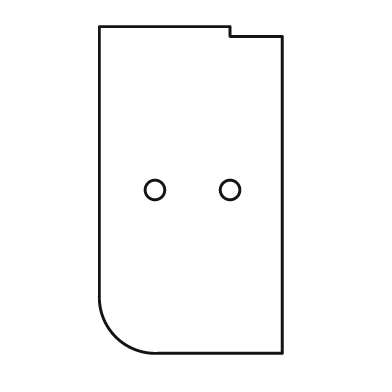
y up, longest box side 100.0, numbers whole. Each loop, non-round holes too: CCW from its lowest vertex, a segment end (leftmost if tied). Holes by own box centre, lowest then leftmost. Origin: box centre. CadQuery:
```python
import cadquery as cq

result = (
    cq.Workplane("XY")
    .moveTo(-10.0, -50.0)
    .lineTo(28.0, -50.0)
    .lineTo(28.0, 47.0)
    .lineTo(12.0, 47.0)
    .lineTo(12.0, 50.0)
    .lineTo(-28.0, 50.0)
    .lineTo(-28.0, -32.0)
    .threePointArc((-23.0, -45.0), (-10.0, -50.0))
    .close()
    .moveTo(-11.0, 0.0)
    .circle(3.0)
    .moveTo(12.0, 0.0)
    .circle(3.0)
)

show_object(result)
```